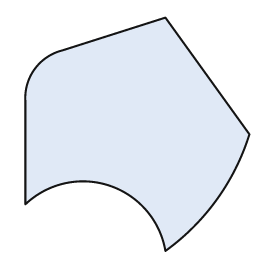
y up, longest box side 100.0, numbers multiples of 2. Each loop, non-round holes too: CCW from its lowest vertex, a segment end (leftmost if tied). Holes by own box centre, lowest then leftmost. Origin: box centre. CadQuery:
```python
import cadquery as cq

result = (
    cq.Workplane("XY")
    .moveTo(12.0, -50.0)
    .threePointArc((34.0, -28.0), (48.0, 0.0))
    .lineTo(12.0, 50.0)
    .lineTo(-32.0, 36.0)
    .threePointArc((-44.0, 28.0), (-48.0, 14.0))
    .lineTo(-48.0, -30.0)
    .threePointArc((-12.0, -22.0), (12.0, -50.0))
    .close()
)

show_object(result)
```